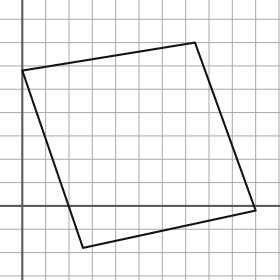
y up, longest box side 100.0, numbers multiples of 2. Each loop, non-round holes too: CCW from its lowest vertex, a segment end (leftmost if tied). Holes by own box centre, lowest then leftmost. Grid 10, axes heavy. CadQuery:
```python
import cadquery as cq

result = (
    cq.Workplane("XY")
    .moveTo(26.0, -18.0)
    .lineTo(100.0, -2.0)
    .lineTo(74.0, 70.0)
    .lineTo(0.0, 58.0)
    .close()
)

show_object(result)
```